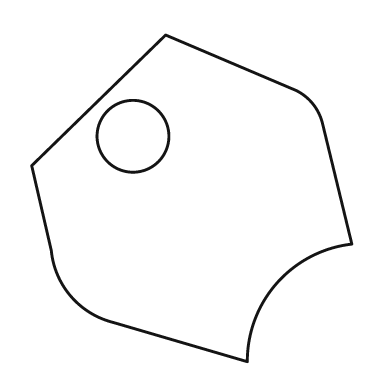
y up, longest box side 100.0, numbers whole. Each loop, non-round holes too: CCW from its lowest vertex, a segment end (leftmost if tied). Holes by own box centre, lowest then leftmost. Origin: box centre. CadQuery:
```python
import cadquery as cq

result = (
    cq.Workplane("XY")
    .moveTo(17.0, -50.0)
    .threePointArc((26.0, -26.0), (49.0, -14.0))
    .lineTo(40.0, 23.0)
    .threePointArc((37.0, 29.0), (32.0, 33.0))
    .lineTo(-8.0, 50.0)
    .lineTo(-49.0, 10.0)
    .lineTo(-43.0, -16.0)
    .threePointArc((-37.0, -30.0), (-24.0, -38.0))
    .close()
    .moveTo(-18.0, 19.0)
    .circle(11.0)
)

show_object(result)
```